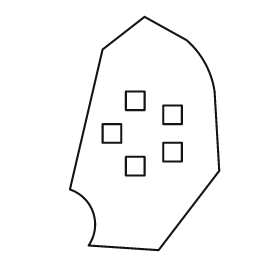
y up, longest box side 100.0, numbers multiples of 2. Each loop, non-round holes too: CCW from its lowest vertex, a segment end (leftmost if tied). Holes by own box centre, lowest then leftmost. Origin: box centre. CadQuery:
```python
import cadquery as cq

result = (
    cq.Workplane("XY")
    .moveTo(6.0, -50.0)
    .lineTo(32.0, -16.0)
    .lineTo(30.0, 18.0)
    .threePointArc((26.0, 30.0), (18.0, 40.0))
    .lineTo(0.0, 50.0)
    .lineTo(-18.0, 36.0)
    .lineTo(-32.0, -24.0)
    .threePointArc((-22.0, -34.0), (-24.0, -48.0))
    .close()
    .moveTo(-8.0, -18.0)
    .lineTo(0.0, -18.0)
    .lineTo(0.0, -10.0)
    .lineTo(-8.0, -10.0)
    .close()
    .moveTo(8.0, -12.0)
    .lineTo(16.0, -12.0)
    .lineTo(16.0, -4.0)
    .lineTo(8.0, -4.0)
    .close()
    .moveTo(-18.0, -4.0)
    .lineTo(-10.0, -4.0)
    .lineTo(-10.0, 4.0)
    .lineTo(-18.0, 4.0)
    .close()
    .moveTo(8.0, 4.0)
    .lineTo(16.0, 4.0)
    .lineTo(16.0, 12.0)
    .lineTo(8.0, 12.0)
    .close()
    .moveTo(-8.0, 10.0)
    .lineTo(0.0, 10.0)
    .lineTo(0.0, 18.0)
    .lineTo(-8.0, 18.0)
    .close()
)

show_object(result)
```